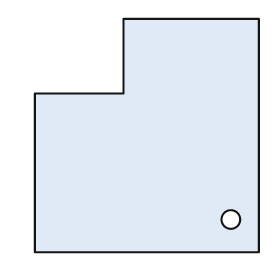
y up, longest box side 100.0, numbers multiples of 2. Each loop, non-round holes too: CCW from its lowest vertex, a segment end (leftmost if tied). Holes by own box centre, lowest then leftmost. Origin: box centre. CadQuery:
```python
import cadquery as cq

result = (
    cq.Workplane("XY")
    .moveTo(-48.0, -50.0)
    .lineTo(48.0, -50.0)
    .lineTo(48.0, 50.0)
    .lineTo(-10.0, 50.0)
    .lineTo(-10.0, 18.0)
    .lineTo(-48.0, 18.0)
    .close()
    .moveTo(36.0, -36.0)
    .circle(4.0)
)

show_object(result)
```